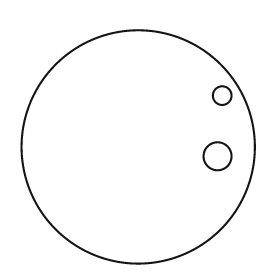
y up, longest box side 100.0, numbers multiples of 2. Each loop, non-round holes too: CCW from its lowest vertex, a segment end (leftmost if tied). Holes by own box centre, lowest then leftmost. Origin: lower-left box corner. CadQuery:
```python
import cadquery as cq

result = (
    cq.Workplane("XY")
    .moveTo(50.0, 50.0)
    .circle(50.0)
    .moveTo(84.0, 46.0)
    .circle(6.0)
    .moveTo(86.0, 72.0)
    .circle(4.0)
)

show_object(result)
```